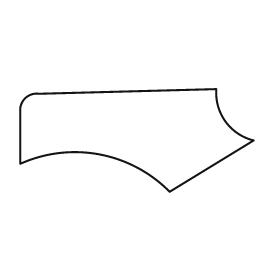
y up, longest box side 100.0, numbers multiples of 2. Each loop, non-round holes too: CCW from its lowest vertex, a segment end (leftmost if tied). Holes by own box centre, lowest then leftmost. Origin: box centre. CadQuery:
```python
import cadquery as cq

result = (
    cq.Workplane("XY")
    .moveTo(14.0, -22.0)
    .lineTo(50.0, 0.0)
    .threePointArc((38.0, 8.0), (34.0, 22.0))
    .lineTo(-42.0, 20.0)
    .threePointArc((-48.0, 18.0), (-50.0, 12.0))
    .lineTo(-50.0, -10.0)
    .threePointArc((-16.0, -6.0), (14.0, -22.0))
    .close()
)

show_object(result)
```